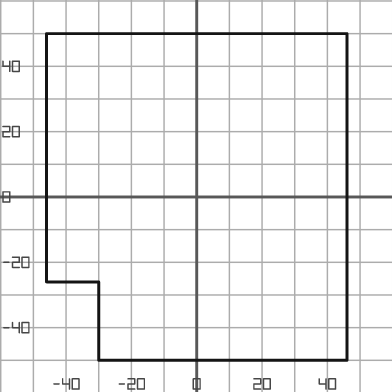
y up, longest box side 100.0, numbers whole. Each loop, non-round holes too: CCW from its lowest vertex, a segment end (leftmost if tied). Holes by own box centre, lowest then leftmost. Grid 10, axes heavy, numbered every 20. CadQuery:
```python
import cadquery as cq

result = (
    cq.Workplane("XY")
    .moveTo(-30.0, -50.0)
    .lineTo(46.0, -50.0)
    .lineTo(46.0, 50.0)
    .lineTo(-46.0, 50.0)
    .lineTo(-46.0, -26.0)
    .lineTo(-30.0, -26.0)
    .close()
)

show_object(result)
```